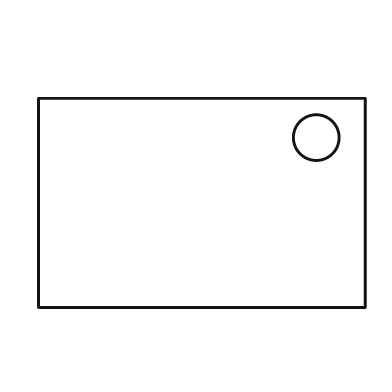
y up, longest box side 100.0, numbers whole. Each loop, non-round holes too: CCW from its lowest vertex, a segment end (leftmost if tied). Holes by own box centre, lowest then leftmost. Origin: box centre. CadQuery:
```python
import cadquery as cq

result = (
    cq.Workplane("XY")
    .moveTo(-50.0, -32.0)
    .lineTo(50.0, -32.0)
    .lineTo(50.0, 32.0)
    .lineTo(-50.0, 32.0)
    .close()
    .moveTo(35.0, 20.0)
    .circle(7.0)
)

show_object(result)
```